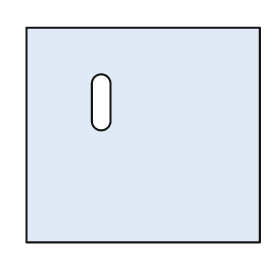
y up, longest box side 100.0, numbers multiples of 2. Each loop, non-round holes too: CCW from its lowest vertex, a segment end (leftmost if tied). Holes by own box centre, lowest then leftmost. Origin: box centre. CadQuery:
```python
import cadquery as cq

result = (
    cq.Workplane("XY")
    .moveTo(-50.0, -46.0)
    .lineTo(50.0, -46.0)
    .lineTo(50.0, 46.0)
    .lineTo(-50.0, 46.0)
    .close()
    .moveTo(-22.0, 6.0)
    .threePointArc((-18.0, 2.0), (-14.0, 6.0))
    .lineTo(-14.0, 22.0)
    .threePointArc((-18.0, 26.0), (-22.0, 22.0))
    .close()
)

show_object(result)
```